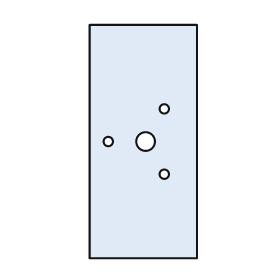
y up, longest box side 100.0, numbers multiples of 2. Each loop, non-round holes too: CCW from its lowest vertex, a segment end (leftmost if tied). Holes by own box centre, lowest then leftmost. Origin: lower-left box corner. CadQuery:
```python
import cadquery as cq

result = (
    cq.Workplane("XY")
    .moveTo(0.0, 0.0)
    .lineTo(46.0, 0.0)
    .lineTo(46.0, 100.0)
    .lineTo(0.0, 100.0)
    .close()
    .moveTo(32.0, 36.0)
    .circle(2.0)
    .moveTo(8.0, 50.0)
    .circle(2.0)
    .moveTo(24.0, 50.0)
    .circle(4.0)
    .moveTo(32.0, 64.0)
    .circle(2.0)
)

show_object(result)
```